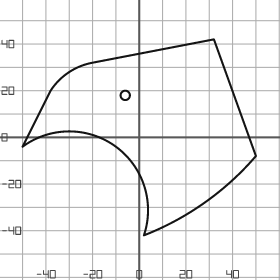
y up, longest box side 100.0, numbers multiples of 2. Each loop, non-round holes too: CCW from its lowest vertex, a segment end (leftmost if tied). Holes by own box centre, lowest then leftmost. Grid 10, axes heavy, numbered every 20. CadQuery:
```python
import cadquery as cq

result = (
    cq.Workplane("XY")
    .moveTo(2.0, -42.0)
    .threePointArc((28.0, -28.0), (50.0, -8.0))
    .lineTo(32.0, 42.0)
    .lineTo(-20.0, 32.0)
    .threePointArc((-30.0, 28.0), (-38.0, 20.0))
    .lineTo(-50.0, -4.0)
    .threePointArc((-10.0, -4.0), (2.0, -42.0))
    .close()
    .moveTo(-6.0, 18.0)
    .circle(2.0)
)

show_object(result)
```